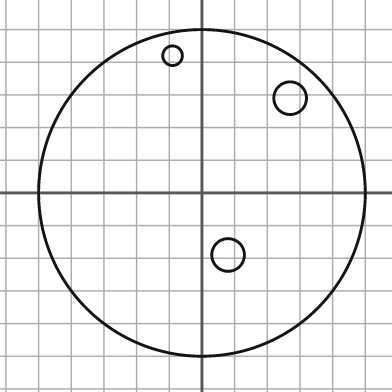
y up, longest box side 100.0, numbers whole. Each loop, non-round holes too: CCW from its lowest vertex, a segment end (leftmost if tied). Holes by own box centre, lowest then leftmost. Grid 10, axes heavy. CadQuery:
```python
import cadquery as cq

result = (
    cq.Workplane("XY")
    .moveTo(0.0, 0.0)
    .circle(50.0)
    .moveTo(8.0, -19.0)
    .circle(5.0)
    .moveTo(27.0, 29.0)
    .circle(5.0)
    .moveTo(-9.0, 42.0)
    .circle(3.0)
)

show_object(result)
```